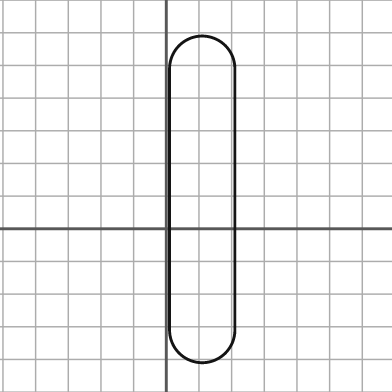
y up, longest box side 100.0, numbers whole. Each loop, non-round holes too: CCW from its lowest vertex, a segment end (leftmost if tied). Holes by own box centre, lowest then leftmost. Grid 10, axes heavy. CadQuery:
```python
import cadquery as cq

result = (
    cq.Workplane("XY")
    .moveTo(1.0, -31.0)
    .threePointArc((11.0, -41.0), (21.0, -31.0))
    .lineTo(21.0, 49.0)
    .threePointArc((11.0, 59.0), (1.0, 49.0))
    .close()
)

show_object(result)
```